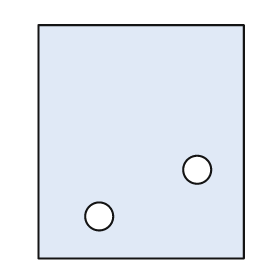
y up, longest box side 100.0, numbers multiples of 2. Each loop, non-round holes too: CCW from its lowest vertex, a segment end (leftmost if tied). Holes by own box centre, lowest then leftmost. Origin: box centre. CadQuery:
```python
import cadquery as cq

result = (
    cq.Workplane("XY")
    .moveTo(-44.0, -50.0)
    .lineTo(44.0, -50.0)
    .lineTo(44.0, 50.0)
    .lineTo(-44.0, 50.0)
    .close()
    .moveTo(-18.0, -32.0)
    .circle(6.0)
    .moveTo(24.0, -12.0)
    .circle(6.0)
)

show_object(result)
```